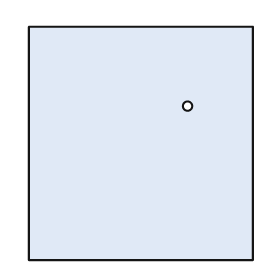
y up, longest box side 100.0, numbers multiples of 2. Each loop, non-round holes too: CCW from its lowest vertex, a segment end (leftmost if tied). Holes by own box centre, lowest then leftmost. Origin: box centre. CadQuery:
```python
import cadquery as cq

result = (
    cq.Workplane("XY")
    .moveTo(-48.0, -50.0)
    .lineTo(48.0, -50.0)
    .lineTo(48.0, 50.0)
    .lineTo(-48.0, 50.0)
    .close()
    .moveTo(20.0, 16.0)
    .circle(2.0)
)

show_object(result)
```